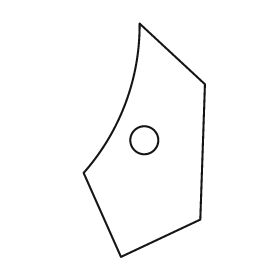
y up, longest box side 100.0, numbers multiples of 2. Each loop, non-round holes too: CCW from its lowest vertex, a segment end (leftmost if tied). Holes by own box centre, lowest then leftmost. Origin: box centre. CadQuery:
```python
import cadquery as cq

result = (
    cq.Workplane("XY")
    .moveTo(-10.0, -50.0)
    .lineTo(24.0, -34.0)
    .lineTo(26.0, 24.0)
    .lineTo(-2.0, 50.0)
    .threePointArc((-8.0, 16.0), (-26.0, -14.0))
    .close()
    .moveTo(0.0, 0.0)
    .circle(6.0)
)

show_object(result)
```